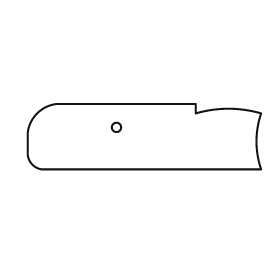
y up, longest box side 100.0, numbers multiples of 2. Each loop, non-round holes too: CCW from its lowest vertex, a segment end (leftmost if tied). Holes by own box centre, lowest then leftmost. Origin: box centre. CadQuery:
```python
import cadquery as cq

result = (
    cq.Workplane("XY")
    .moveTo(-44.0, -14.0)
    .lineTo(50.0, -14.0)
    .threePointArc((48.0, -2.0), (50.0, 10.0))
    .threePointArc((36.0, 12.0), (22.0, 10.0))
    .lineTo(22.0, 14.0)
    .lineTo(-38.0, 14.0)
    .threePointArc((-46.0, 10.0), (-50.0, 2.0))
    .lineTo(-50.0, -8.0)
    .threePointArc((-48.0, -12.0), (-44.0, -14.0))
    .close()
    .moveTo(-12.0, 4.0)
    .circle(2.0)
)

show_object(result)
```